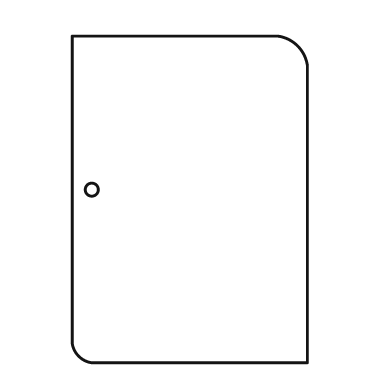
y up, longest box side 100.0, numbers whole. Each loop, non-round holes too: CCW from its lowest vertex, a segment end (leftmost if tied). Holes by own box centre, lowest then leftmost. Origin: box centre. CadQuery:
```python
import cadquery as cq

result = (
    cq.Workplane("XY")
    .moveTo(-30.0, -50.0)
    .lineTo(36.0, -50.0)
    .lineTo(36.0, 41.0)
    .threePointArc((33.0, 47.0), (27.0, 50.0))
    .lineTo(-36.0, 50.0)
    .lineTo(-36.0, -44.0)
    .threePointArc((-34.0, -48.0), (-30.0, -50.0))
    .close()
    .moveTo(-30.0, 3.0)
    .circle(2.0)
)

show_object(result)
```